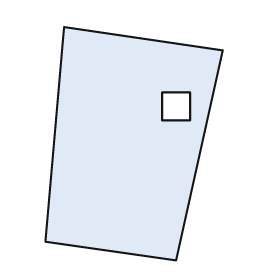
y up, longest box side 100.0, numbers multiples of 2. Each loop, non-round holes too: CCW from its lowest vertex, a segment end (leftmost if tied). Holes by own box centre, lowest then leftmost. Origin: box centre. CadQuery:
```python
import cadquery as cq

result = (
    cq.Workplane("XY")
    .moveTo(18.0, -50.0)
    .lineTo(38.0, 40.0)
    .lineTo(-30.0, 50.0)
    .lineTo(-38.0, -42.0)
    .close()
    .moveTo(12.0, 10.0)
    .lineTo(24.0, 10.0)
    .lineTo(24.0, 22.0)
    .lineTo(12.0, 22.0)
    .close()
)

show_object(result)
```